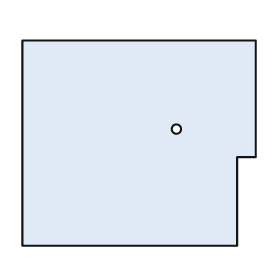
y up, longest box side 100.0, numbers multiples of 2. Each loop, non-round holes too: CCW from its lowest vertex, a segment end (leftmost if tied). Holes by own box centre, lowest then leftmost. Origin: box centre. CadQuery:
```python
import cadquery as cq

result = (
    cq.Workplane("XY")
    .moveTo(-50.0, -44.0)
    .lineTo(42.0, -44.0)
    .lineTo(42.0, -6.0)
    .lineTo(50.0, -6.0)
    .lineTo(50.0, 44.0)
    .lineTo(-50.0, 44.0)
    .close()
    .moveTo(16.0, 6.0)
    .circle(2.0)
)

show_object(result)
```